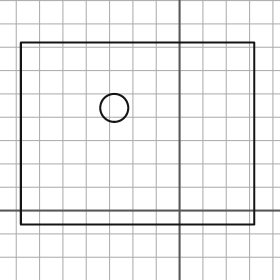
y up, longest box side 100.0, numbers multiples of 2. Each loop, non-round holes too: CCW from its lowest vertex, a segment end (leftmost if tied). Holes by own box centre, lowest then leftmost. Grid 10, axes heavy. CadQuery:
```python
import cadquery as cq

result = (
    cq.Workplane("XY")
    .moveTo(-68.0, -6.0)
    .lineTo(32.0, -6.0)
    .lineTo(32.0, 72.0)
    .lineTo(-68.0, 72.0)
    .close()
    .moveTo(-28.0, 44.0)
    .circle(6.0)
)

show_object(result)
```